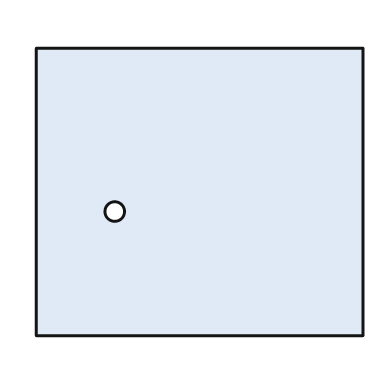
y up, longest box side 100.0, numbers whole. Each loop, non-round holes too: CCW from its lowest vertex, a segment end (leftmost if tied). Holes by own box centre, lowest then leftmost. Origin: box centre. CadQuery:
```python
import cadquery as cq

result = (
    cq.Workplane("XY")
    .moveTo(-50.0, -44.0)
    .lineTo(50.0, -44.0)
    .lineTo(50.0, 44.0)
    .lineTo(-50.0, 44.0)
    .close()
    .moveTo(-26.0, -6.0)
    .circle(3.0)
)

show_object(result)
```